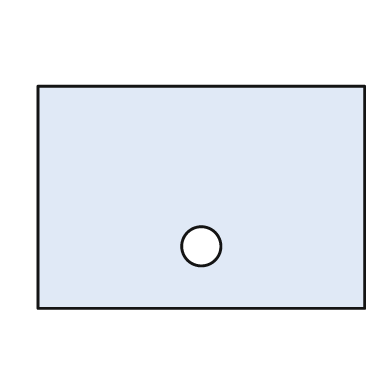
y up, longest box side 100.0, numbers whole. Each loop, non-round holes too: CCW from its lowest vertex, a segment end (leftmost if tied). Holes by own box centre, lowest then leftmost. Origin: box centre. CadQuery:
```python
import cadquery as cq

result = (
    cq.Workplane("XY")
    .moveTo(-50.0, -34.0)
    .lineTo(50.0, -34.0)
    .lineTo(50.0, 34.0)
    .lineTo(-50.0, 34.0)
    .close()
    .moveTo(0.0, -15.0)
    .circle(6.0)
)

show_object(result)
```